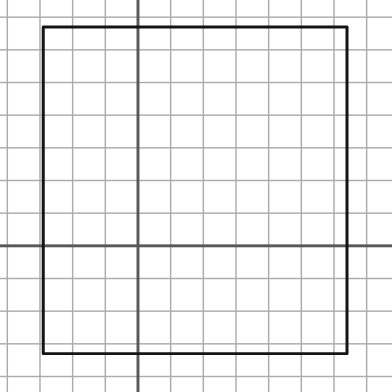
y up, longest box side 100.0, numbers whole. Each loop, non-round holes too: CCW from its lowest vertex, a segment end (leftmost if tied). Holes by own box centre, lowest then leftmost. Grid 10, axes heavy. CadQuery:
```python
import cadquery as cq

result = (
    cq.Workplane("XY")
    .moveTo(-29.0, -33.0)
    .lineTo(64.0, -33.0)
    .lineTo(64.0, 67.0)
    .lineTo(-29.0, 67.0)
    .close()
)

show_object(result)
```